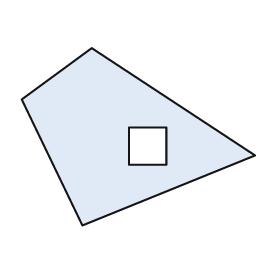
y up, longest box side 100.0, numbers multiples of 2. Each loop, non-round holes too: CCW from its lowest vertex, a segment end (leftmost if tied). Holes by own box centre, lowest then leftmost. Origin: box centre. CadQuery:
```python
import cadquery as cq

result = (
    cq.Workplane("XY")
    .moveTo(-24.0, -38.0)
    .lineTo(50.0, -8.0)
    .lineTo(-20.0, 38.0)
    .lineTo(-50.0, 16.0)
    .close()
    .moveTo(-4.0, -12.0)
    .lineTo(12.0, -12.0)
    .lineTo(12.0, 4.0)
    .lineTo(-4.0, 4.0)
    .close()
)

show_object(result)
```